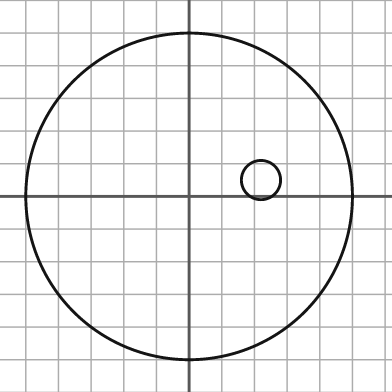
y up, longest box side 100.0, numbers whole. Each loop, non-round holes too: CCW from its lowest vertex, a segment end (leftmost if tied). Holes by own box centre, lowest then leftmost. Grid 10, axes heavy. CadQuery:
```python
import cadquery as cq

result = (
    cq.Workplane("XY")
    .moveTo(0.0, 0.0)
    .circle(50.0)
    .moveTo(22.0, 5.0)
    .circle(6.0)
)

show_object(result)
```